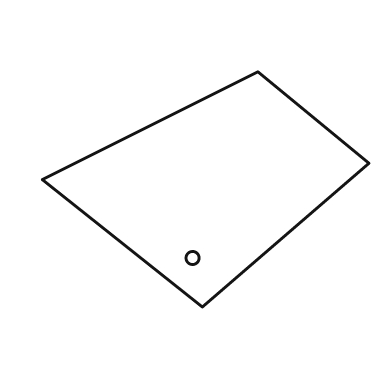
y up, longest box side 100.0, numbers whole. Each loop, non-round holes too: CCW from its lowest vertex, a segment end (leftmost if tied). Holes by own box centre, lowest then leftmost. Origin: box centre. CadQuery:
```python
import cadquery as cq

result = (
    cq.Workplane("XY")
    .moveTo(-1.0, -36.0)
    .lineTo(50.0, 8.0)
    .lineTo(16.0, 36.0)
    .lineTo(-50.0, 3.0)
    .close()
    .moveTo(-4.0, -21.0)
    .circle(2.0)
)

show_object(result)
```